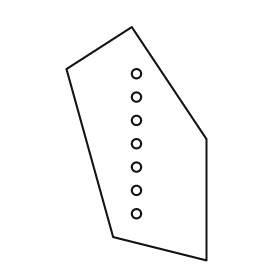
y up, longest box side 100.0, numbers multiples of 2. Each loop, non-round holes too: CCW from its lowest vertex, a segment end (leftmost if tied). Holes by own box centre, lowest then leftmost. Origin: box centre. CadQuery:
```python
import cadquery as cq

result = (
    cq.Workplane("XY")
    .moveTo(30.0, -50.0)
    .lineTo(30.0, 2.0)
    .lineTo(-2.0, 50.0)
    .lineTo(-30.0, 32.0)
    .lineTo(-10.0, -40.0)
    .close()
    .moveTo(0.0, -30.0)
    .circle(2.0)
    .moveTo(0.0, -20.0)
    .circle(2.0)
    .moveTo(0.0, -10.0)
    .circle(2.0)
    .moveTo(0.0, 0.0)
    .circle(2.0)
    .moveTo(0.0, 10.0)
    .circle(2.0)
    .moveTo(0.0, 20.0)
    .circle(2.0)
    .moveTo(0.0, 30.0)
    .circle(2.0)
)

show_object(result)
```